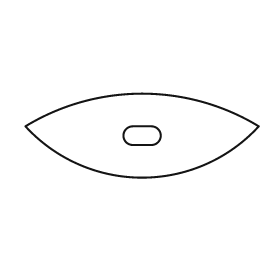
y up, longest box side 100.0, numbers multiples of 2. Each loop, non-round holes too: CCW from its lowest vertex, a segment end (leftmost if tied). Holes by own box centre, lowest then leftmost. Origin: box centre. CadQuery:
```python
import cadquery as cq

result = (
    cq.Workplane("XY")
    .moveTo(-50.0, 4.0)
    .threePointArc((0.0, -18.0), (50.0, 4.0))
    .threePointArc((0.0, 18.0), (-50.0, 4.0))
    .close()
    .moveTo(-4.0, -4.0)
    .lineTo(4.0, -4.0)
    .threePointArc((8.0, 0.0), (4.0, 4.0))
    .lineTo(-4.0, 4.0)
    .threePointArc((-8.0, 0.0), (-4.0, -4.0))
    .close()
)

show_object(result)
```